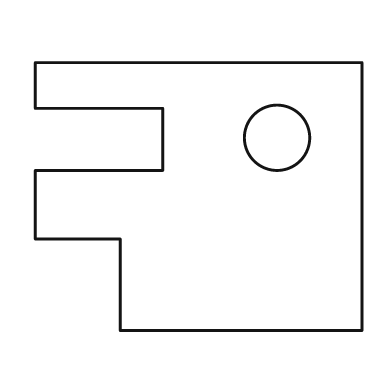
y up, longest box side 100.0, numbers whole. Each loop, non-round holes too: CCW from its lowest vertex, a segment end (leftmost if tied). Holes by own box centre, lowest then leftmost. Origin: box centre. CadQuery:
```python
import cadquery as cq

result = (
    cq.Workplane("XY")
    .moveTo(-24.0, -41.0)
    .lineTo(50.0, -41.0)
    .lineTo(50.0, 41.0)
    .lineTo(-50.0, 41.0)
    .lineTo(-50.0, 27.0)
    .lineTo(-11.0, 27.0)
    .lineTo(-11.0, 8.0)
    .lineTo(-50.0, 8.0)
    .lineTo(-50.0, -13.0)
    .lineTo(-24.0, -13.0)
    .close()
    .moveTo(24.0, 18.0)
    .circle(10.0)
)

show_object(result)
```